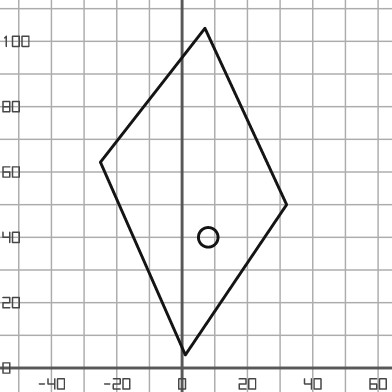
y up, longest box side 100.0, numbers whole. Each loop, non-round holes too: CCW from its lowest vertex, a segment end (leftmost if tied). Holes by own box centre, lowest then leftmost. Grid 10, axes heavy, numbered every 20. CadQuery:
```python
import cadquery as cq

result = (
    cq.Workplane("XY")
    .moveTo(1.0, 4.0)
    .lineTo(32.0, 50.0)
    .lineTo(7.0, 104.0)
    .lineTo(-25.0, 63.0)
    .close()
    .moveTo(8.0, 40.0)
    .circle(3.0)
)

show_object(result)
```